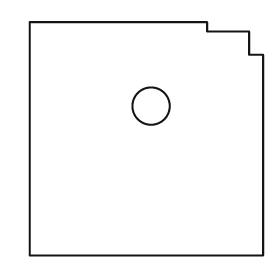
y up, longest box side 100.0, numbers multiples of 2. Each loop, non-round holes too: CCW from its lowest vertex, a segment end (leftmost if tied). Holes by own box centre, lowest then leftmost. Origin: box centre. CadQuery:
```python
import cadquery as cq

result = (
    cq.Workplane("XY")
    .moveTo(-50.0, -50.0)
    .lineTo(50.0, -50.0)
    .lineTo(50.0, 36.0)
    .lineTo(44.0, 36.0)
    .lineTo(44.0, 46.0)
    .lineTo(26.0, 46.0)
    .lineTo(26.0, 50.0)
    .lineTo(-50.0, 50.0)
    .close()
    .moveTo(2.0, 14.0)
    .circle(8.0)
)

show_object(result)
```